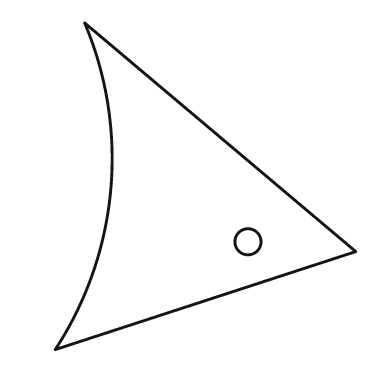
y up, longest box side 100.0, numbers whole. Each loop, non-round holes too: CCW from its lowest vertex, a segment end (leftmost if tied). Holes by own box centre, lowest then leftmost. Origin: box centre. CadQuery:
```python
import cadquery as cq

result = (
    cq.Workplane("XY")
    .moveTo(-46.0, -50.0)
    .lineTo(46.0, -20.0)
    .lineTo(-37.0, 50.0)
    .threePointArc((-29.0, -1.0), (-46.0, -50.0))
    .close()
    .moveTo(13.0, -17.0)
    .circle(4.0)
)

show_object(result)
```